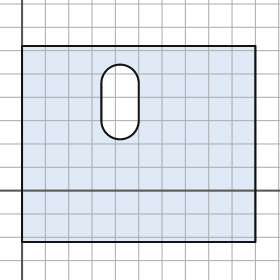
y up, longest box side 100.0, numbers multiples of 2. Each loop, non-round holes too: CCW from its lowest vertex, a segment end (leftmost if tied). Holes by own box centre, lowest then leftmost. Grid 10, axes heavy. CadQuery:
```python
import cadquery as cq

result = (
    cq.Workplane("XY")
    .moveTo(0.0, -22.0)
    .lineTo(100.0, -22.0)
    .lineTo(100.0, 62.0)
    .lineTo(0.0, 62.0)
    .close()
    .moveTo(34.0, 30.0)
    .threePointArc((42.0, 22.0), (50.0, 30.0))
    .lineTo(50.0, 46.0)
    .threePointArc((42.0, 54.0), (34.0, 46.0))
    .close()
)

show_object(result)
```